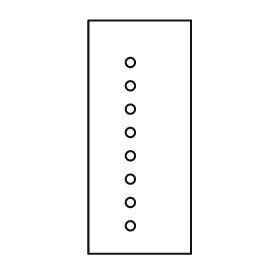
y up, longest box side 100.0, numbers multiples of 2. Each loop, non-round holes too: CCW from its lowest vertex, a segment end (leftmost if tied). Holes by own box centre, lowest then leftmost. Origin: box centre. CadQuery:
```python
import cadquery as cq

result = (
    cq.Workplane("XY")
    .moveTo(-22.0, -50.0)
    .lineTo(22.0, -50.0)
    .lineTo(22.0, 50.0)
    .lineTo(-22.0, 50.0)
    .close()
    .moveTo(-4.0, -38.0)
    .circle(2.0)
    .moveTo(-4.0, -28.0)
    .circle(2.0)
    .moveTo(-4.0, -18.0)
    .circle(2.0)
    .moveTo(-4.0, -8.0)
    .circle(2.0)
    .moveTo(-4.0, 2.0)
    .circle(2.0)
    .moveTo(-4.0, 12.0)
    .circle(2.0)
    .moveTo(-4.0, 22.0)
    .circle(2.0)
    .moveTo(-4.0, 32.0)
    .circle(2.0)
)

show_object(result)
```